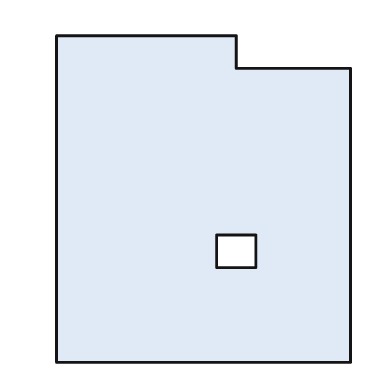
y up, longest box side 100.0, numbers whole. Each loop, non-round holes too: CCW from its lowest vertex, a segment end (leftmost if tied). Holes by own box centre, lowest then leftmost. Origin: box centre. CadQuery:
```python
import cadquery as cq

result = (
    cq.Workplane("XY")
    .moveTo(-45.0, -50.0)
    .lineTo(45.0, -50.0)
    .lineTo(45.0, 40.0)
    .lineTo(10.0, 40.0)
    .lineTo(10.0, 50.0)
    .lineTo(-45.0, 50.0)
    .close()
    .moveTo(4.0, -21.0)
    .lineTo(16.0, -21.0)
    .lineTo(16.0, -11.0)
    .lineTo(4.0, -11.0)
    .close()
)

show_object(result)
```